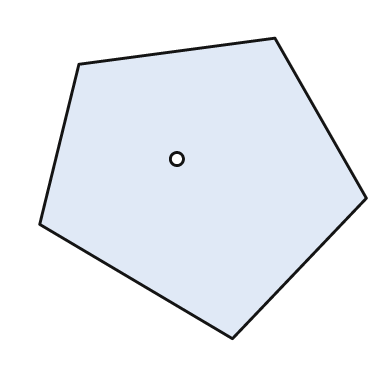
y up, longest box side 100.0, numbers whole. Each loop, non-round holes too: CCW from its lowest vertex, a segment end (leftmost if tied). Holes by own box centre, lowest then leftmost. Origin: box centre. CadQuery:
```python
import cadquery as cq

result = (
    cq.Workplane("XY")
    .moveTo(9.0, -46.0)
    .lineTo(50.0, -3.0)
    .lineTo(22.0, 46.0)
    .lineTo(-38.0, 38.0)
    .lineTo(-50.0, -11.0)
    .close()
    .moveTo(-8.0, 9.0)
    .circle(2.0)
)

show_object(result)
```